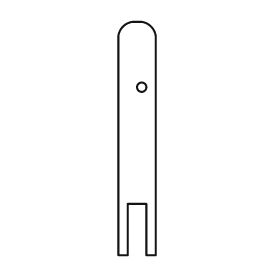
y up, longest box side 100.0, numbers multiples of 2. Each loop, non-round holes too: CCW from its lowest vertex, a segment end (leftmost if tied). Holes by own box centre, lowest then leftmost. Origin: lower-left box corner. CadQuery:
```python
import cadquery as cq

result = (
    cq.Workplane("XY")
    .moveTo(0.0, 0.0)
    .lineTo(4.0, 0.0)
    .lineTo(4.0, 22.0)
    .lineTo(12.0, 22.0)
    .lineTo(12.0, 0.0)
    .lineTo(16.0, 0.0)
    .lineTo(16.0, 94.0)
    .threePointArc((14.0, 98.0), (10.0, 100.0))
    .lineTo(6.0, 100.0)
    .threePointArc((2.0, 98.0), (0.0, 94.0))
    .close()
    .moveTo(10.0, 72.0)
    .circle(2.0)
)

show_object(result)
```